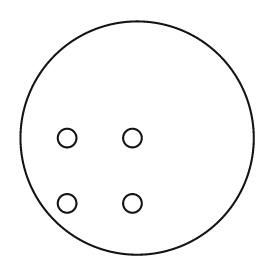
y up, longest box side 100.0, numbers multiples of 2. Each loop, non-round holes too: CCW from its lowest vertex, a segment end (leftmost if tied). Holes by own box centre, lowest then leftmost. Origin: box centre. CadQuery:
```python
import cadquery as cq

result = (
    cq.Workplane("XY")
    .moveTo(0.0, 0.0)
    .circle(50.0)
    .moveTo(-30.0, -28.0)
    .circle(4.0)
    .moveTo(-2.0, -28.0)
    .circle(4.0)
    .moveTo(-30.0, 0.0)
    .circle(4.0)
    .moveTo(-2.0, 0.0)
    .circle(4.0)
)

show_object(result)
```